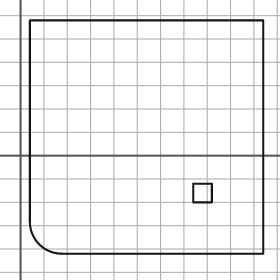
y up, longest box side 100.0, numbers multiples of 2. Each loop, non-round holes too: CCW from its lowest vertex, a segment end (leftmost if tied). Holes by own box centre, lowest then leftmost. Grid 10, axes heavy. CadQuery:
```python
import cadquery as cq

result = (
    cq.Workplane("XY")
    .moveTo(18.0, -42.0)
    .lineTo(104.0, -42.0)
    .lineTo(104.0, 58.0)
    .lineTo(4.0, 58.0)
    .lineTo(4.0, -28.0)
    .threePointArc((8.0, -38.0), (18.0, -42.0))
    .close()
    .moveTo(74.0, -20.0)
    .lineTo(82.0, -20.0)
    .lineTo(82.0, -12.0)
    .lineTo(74.0, -12.0)
    .close()
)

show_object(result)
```